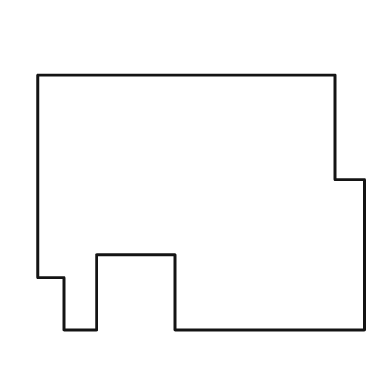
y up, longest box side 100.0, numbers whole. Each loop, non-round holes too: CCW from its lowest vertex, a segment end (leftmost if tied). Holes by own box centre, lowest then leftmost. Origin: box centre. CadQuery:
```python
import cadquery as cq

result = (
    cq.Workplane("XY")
    .moveTo(-42.0, -39.0)
    .lineTo(-32.0, -39.0)
    .lineTo(-32.0, -16.0)
    .lineTo(-8.0, -16.0)
    .lineTo(-8.0, -39.0)
    .lineTo(50.0, -39.0)
    .lineTo(50.0, 7.0)
    .lineTo(41.0, 7.0)
    .lineTo(41.0, 39.0)
    .lineTo(-50.0, 39.0)
    .lineTo(-50.0, -23.0)
    .lineTo(-42.0, -23.0)
    .close()
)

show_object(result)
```